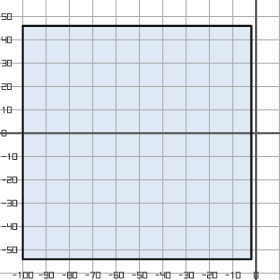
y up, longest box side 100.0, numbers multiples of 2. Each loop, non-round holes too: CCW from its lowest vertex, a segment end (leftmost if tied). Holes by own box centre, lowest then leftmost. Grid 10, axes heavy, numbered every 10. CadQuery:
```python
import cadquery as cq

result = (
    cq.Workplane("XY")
    .moveTo(-100.0, -54.0)
    .lineTo(-2.0, -54.0)
    .lineTo(-2.0, 46.0)
    .lineTo(-100.0, 46.0)
    .close()
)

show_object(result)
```